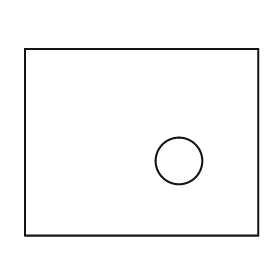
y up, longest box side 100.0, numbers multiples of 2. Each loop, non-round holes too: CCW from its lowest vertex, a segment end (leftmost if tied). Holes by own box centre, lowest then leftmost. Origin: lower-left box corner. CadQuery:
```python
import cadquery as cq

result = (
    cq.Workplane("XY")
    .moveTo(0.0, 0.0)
    .lineTo(100.0, 0.0)
    .lineTo(100.0, 80.0)
    .lineTo(0.0, 80.0)
    .close()
    .moveTo(66.0, 32.0)
    .circle(10.0)
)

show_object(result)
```